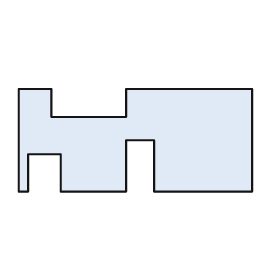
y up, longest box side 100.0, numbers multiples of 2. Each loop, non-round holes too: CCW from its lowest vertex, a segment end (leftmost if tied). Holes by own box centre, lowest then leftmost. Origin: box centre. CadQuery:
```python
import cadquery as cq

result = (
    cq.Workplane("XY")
    .moveTo(-50.0, -22.0)
    .lineTo(-46.0, -22.0)
    .lineTo(-46.0, -6.0)
    .lineTo(-32.0, -6.0)
    .lineTo(-32.0, -22.0)
    .lineTo(-4.0, -22.0)
    .lineTo(-4.0, 0.0)
    .lineTo(8.0, 0.0)
    .lineTo(8.0, -22.0)
    .lineTo(50.0, -22.0)
    .lineTo(50.0, 22.0)
    .lineTo(-4.0, 22.0)
    .lineTo(-4.0, 10.0)
    .lineTo(-36.0, 10.0)
    .lineTo(-36.0, 22.0)
    .lineTo(-50.0, 22.0)
    .close()
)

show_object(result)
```